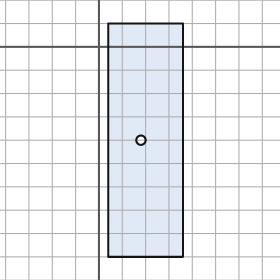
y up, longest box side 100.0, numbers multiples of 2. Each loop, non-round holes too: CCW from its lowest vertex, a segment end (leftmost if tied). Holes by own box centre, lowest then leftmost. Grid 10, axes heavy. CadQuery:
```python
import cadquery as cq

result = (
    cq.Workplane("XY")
    .moveTo(4.0, -90.0)
    .lineTo(36.0, -90.0)
    .lineTo(36.0, 10.0)
    .lineTo(4.0, 10.0)
    .close()
    .moveTo(18.0, -40.0)
    .circle(2.0)
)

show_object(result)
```